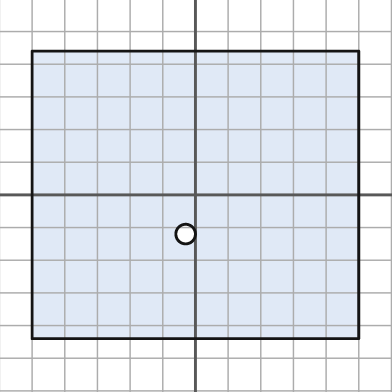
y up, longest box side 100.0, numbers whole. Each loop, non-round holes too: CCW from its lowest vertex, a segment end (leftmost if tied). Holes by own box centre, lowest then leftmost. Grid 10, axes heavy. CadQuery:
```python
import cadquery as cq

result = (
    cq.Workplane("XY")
    .moveTo(-50.0, -44.0)
    .lineTo(50.0, -44.0)
    .lineTo(50.0, 44.0)
    .lineTo(-50.0, 44.0)
    .close()
    .moveTo(-3.0, -12.0)
    .circle(3.0)
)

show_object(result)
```